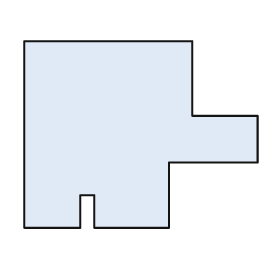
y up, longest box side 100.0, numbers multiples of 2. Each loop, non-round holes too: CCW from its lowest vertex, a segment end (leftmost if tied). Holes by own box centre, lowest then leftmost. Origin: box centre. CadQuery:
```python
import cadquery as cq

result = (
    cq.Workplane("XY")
    .moveTo(-50.0, -40.0)
    .lineTo(-26.0, -40.0)
    .lineTo(-26.0, -26.0)
    .lineTo(-20.0, -26.0)
    .lineTo(-20.0, -40.0)
    .lineTo(12.0, -40.0)
    .lineTo(12.0, -12.0)
    .lineTo(50.0, -12.0)
    .lineTo(50.0, 8.0)
    .lineTo(22.0, 8.0)
    .lineTo(22.0, 40.0)
    .lineTo(-50.0, 40.0)
    .close()
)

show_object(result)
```